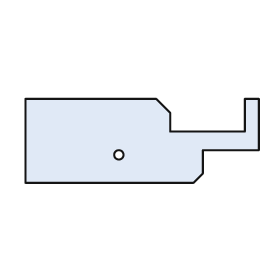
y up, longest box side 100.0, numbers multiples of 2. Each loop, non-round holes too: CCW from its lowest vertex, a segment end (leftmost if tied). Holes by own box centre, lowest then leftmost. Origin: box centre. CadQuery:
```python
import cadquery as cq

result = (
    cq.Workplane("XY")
    .moveTo(-50.0, -18.0)
    .lineTo(22.0, -18.0)
    .lineTo(26.0, -14.0)
    .lineTo(26.0, -4.0)
    .lineTo(50.0, -4.0)
    .lineTo(50.0, 18.0)
    .lineTo(44.0, 18.0)
    .lineTo(44.0, 4.0)
    .lineTo(12.0, 4.0)
    .lineTo(12.0, 12.0)
    .lineTo(6.0, 18.0)
    .lineTo(-50.0, 18.0)
    .close()
    .moveTo(-10.0, -6.0)
    .circle(2.0)
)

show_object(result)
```